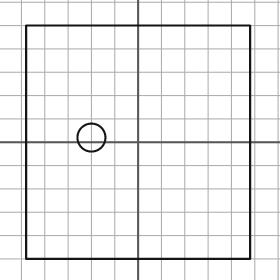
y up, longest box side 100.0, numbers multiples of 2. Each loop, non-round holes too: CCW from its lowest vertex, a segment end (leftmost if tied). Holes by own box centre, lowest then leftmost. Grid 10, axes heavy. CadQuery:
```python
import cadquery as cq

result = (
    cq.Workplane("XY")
    .moveTo(-48.0, -50.0)
    .lineTo(48.0, -50.0)
    .lineTo(48.0, 50.0)
    .lineTo(-48.0, 50.0)
    .close()
    .moveTo(-20.0, 2.0)
    .circle(6.0)
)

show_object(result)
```